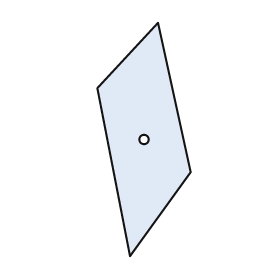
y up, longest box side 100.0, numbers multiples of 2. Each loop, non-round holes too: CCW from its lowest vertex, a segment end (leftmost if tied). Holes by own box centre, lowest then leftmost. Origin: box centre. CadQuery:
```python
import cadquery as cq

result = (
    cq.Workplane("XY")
    .moveTo(-6.0, -50.0)
    .lineTo(20.0, -14.0)
    .lineTo(6.0, 50.0)
    .lineTo(-20.0, 22.0)
    .close()
    .moveTo(0.0, 0.0)
    .circle(2.0)
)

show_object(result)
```